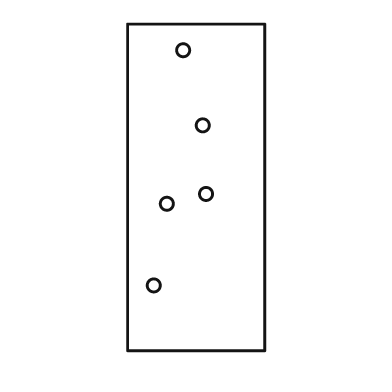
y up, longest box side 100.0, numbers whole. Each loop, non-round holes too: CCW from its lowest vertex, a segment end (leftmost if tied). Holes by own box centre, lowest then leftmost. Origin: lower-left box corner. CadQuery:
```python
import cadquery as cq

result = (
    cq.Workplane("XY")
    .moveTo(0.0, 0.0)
    .lineTo(42.0, 0.0)
    .lineTo(42.0, 100.0)
    .lineTo(0.0, 100.0)
    .close()
    .moveTo(8.0, 20.0)
    .circle(2.0)
    .moveTo(12.0, 45.0)
    .circle(2.0)
    .moveTo(24.0, 48.0)
    .circle(2.0)
    .moveTo(23.0, 69.0)
    .circle(2.0)
    .moveTo(17.0, 92.0)
    .circle(2.0)
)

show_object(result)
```